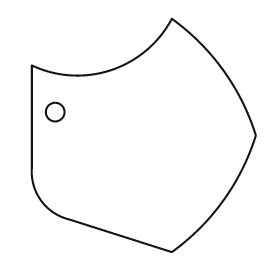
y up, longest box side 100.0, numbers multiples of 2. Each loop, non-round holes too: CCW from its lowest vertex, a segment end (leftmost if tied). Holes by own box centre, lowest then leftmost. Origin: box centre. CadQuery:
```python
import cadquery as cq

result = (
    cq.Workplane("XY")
    .moveTo(12.0, -50.0)
    .threePointArc((34.0, -28.0), (48.0, 0.0))
    .threePointArc((34.0, 28.0), (12.0, 50.0))
    .threePointArc((-14.0, 28.0), (-48.0, 30.0))
    .lineTo(-48.0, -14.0)
    .threePointArc((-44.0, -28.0), (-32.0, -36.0))
    .close()
    .moveTo(-38.0, 10.0)
    .circle(4.0)
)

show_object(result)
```